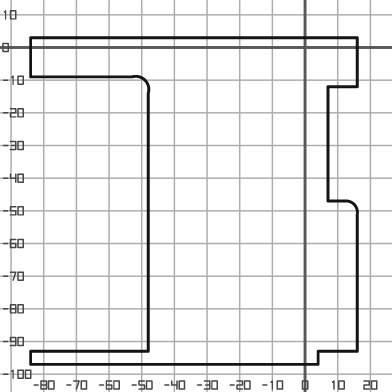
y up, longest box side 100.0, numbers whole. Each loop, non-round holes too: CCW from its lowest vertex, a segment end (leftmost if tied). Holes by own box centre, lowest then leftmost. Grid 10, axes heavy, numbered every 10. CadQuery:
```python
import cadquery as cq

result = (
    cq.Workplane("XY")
    .moveTo(-84.0, -97.0)
    .lineTo(4.0, -97.0)
    .lineTo(4.0, -93.0)
    .lineTo(16.0, -93.0)
    .lineTo(16.0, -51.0)
    .threePointArc((15.0, -48.0), (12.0, -47.0))
    .lineTo(7.0, -47.0)
    .lineTo(7.0, -12.0)
    .lineTo(16.0, -12.0)
    .lineTo(16.0, 3.0)
    .lineTo(-84.0, 3.0)
    .lineTo(-84.0, -9.0)
    .lineTo(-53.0, -9.0)
    .threePointArc((-49.0, -10.0), (-48.0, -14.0))
    .lineTo(-48.0, -93.0)
    .lineTo(-84.0, -93.0)
    .close()
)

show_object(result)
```